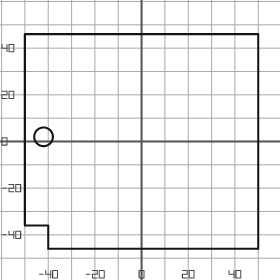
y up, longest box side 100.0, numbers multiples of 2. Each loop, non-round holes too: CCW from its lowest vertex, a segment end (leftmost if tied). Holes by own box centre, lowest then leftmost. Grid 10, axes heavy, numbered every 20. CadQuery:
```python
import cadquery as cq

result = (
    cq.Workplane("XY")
    .moveTo(-40.0, -46.0)
    .lineTo(50.0, -46.0)
    .lineTo(50.0, 46.0)
    .lineTo(-50.0, 46.0)
    .lineTo(-50.0, -36.0)
    .lineTo(-40.0, -36.0)
    .close()
    .moveTo(-42.0, 2.0)
    .circle(4.0)
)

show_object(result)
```